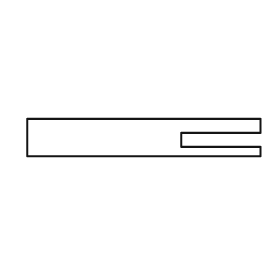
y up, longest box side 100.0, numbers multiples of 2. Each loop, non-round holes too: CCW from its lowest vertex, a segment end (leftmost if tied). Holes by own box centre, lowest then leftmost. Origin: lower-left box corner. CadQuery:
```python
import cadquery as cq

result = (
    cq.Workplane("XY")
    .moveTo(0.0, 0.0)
    .lineTo(100.0, 0.0)
    .lineTo(100.0, 4.0)
    .lineTo(66.0, 4.0)
    .lineTo(66.0, 10.0)
    .lineTo(100.0, 10.0)
    .lineTo(100.0, 16.0)
    .lineTo(0.0, 16.0)
    .close()
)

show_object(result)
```